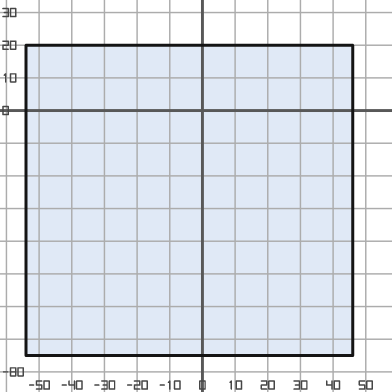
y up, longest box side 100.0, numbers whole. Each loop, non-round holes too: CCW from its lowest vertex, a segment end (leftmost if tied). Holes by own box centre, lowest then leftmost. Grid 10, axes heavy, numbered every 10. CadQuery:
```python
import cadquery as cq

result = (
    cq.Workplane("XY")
    .moveTo(-54.0, -75.0)
    .lineTo(46.0, -75.0)
    .lineTo(46.0, 20.0)
    .lineTo(-54.0, 20.0)
    .close()
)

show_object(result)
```